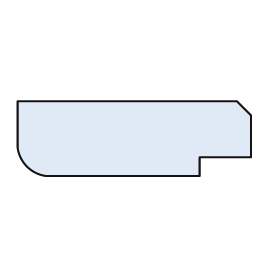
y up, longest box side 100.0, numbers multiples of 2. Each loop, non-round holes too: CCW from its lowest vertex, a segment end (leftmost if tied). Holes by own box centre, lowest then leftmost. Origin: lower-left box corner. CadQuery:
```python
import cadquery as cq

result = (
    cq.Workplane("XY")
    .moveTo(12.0, 0.0)
    .lineTo(78.0, 0.0)
    .lineTo(78.0, 8.0)
    .lineTo(100.0, 8.0)
    .lineTo(100.0, 26.0)
    .lineTo(94.0, 32.0)
    .lineTo(0.0, 32.0)
    .lineTo(0.0, 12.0)
    .threePointArc((4.0, 4.0), (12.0, 0.0))
    .close()
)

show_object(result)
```